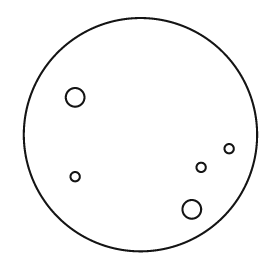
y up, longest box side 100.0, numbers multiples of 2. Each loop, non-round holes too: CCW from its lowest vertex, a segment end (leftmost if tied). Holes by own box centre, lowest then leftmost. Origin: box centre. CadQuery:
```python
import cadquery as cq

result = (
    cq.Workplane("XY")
    .moveTo(0.0, 0.0)
    .circle(50.0)
    .moveTo(22.0, -32.0)
    .circle(4.0)
    .moveTo(-28.0, -18.0)
    .circle(2.0)
    .moveTo(26.0, -14.0)
    .circle(2.0)
    .moveTo(38.0, -6.0)
    .circle(2.0)
    .moveTo(-28.0, 16.0)
    .circle(4.0)
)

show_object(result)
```